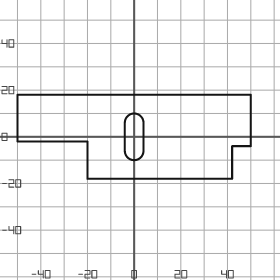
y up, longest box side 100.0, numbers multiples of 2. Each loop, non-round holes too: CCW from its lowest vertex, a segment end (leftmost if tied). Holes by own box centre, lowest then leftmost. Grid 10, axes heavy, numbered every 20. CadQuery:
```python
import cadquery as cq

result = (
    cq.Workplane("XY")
    .moveTo(-20.0, -18.0)
    .lineTo(42.0, -18.0)
    .lineTo(42.0, -4.0)
    .lineTo(50.0, -4.0)
    .lineTo(50.0, 18.0)
    .lineTo(-50.0, 18.0)
    .lineTo(-50.0, -2.0)
    .lineTo(-20.0, -2.0)
    .close()
    .moveTo(-4.0, -6.0)
    .threePointArc((0.0, -10.0), (4.0, -6.0))
    .lineTo(4.0, 6.0)
    .threePointArc((0.0, 10.0), (-4.0, 6.0))
    .close()
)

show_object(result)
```